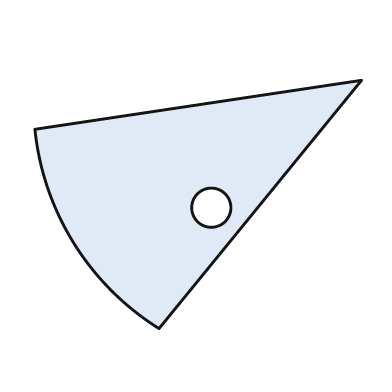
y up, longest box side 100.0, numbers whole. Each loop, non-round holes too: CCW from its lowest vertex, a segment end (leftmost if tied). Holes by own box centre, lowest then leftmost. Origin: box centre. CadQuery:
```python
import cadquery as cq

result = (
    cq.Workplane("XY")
    .moveTo(-12.0, -38.0)
    .lineTo(50.0, 38.0)
    .lineTo(-50.0, 23.0)
    .threePointArc((-38.0, -12.0), (-12.0, -38.0))
    .close()
    .moveTo(4.0, -1.0)
    .circle(6.0)
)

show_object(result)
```